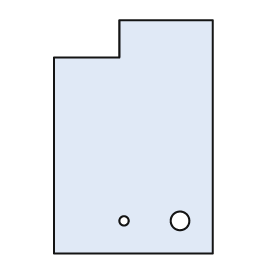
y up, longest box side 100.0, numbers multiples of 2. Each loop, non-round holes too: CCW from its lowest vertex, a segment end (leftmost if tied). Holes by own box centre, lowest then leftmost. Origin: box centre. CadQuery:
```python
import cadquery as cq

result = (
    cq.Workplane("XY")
    .moveTo(-34.0, -50.0)
    .lineTo(34.0, -50.0)
    .lineTo(34.0, 50.0)
    .lineTo(-6.0, 50.0)
    .lineTo(-6.0, 34.0)
    .lineTo(-34.0, 34.0)
    .close()
    .moveTo(-4.0, -36.0)
    .circle(2.0)
    .moveTo(20.0, -36.0)
    .circle(4.0)
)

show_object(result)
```